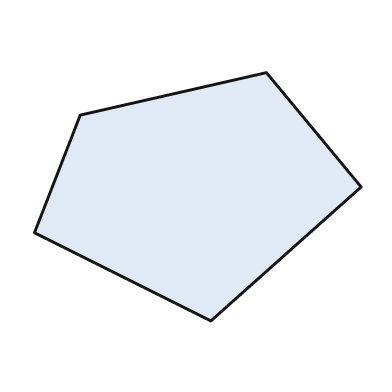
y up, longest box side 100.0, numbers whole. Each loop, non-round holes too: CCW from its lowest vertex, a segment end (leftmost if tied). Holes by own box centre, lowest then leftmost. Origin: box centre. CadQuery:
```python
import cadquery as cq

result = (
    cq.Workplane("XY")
    .moveTo(4.0, -38.0)
    .lineTo(50.0, 3.0)
    .lineTo(21.0, 38.0)
    .lineTo(-36.0, 25.0)
    .lineTo(-50.0, -11.0)
    .close()
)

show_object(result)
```